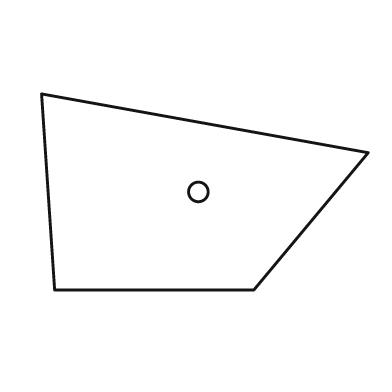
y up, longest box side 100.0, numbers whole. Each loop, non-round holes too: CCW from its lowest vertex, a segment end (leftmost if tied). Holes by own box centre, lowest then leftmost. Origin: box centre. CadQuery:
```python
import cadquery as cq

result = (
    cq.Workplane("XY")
    .moveTo(-46.0, -30.0)
    .lineTo(15.0, -30.0)
    .lineTo(50.0, 12.0)
    .lineTo(-50.0, 30.0)
    .close()
    .moveTo(-2.0, 0.0)
    .circle(3.0)
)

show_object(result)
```